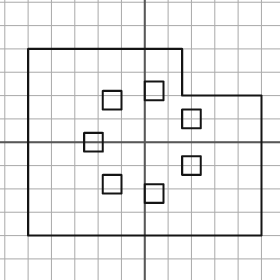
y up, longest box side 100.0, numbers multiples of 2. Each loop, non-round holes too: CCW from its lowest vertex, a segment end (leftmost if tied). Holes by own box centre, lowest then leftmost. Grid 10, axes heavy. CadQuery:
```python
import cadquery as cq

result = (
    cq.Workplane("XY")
    .moveTo(-50.0, -40.0)
    .lineTo(50.0, -40.0)
    .lineTo(50.0, 20.0)
    .lineTo(16.0, 20.0)
    .lineTo(16.0, 40.0)
    .lineTo(-50.0, 40.0)
    .close()
    .moveTo(0.0, -26.0)
    .lineTo(8.0, -26.0)
    .lineTo(8.0, -18.0)
    .lineTo(0.0, -18.0)
    .close()
    .moveTo(-18.0, -22.0)
    .lineTo(-10.0, -22.0)
    .lineTo(-10.0, -14.0)
    .lineTo(-18.0, -14.0)
    .close()
    .moveTo(16.0, -14.0)
    .lineTo(24.0, -14.0)
    .lineTo(24.0, -6.0)
    .lineTo(16.0, -6.0)
    .close()
    .moveTo(-26.0, -4.0)
    .lineTo(-18.0, -4.0)
    .lineTo(-18.0, 4.0)
    .lineTo(-26.0, 4.0)
    .close()
    .moveTo(16.0, 6.0)
    .lineTo(24.0, 6.0)
    .lineTo(24.0, 14.0)
    .lineTo(16.0, 14.0)
    .close()
    .moveTo(-18.0, 14.0)
    .lineTo(-10.0, 14.0)
    .lineTo(-10.0, 22.0)
    .lineTo(-18.0, 22.0)
    .close()
    .moveTo(0.0, 18.0)
    .lineTo(8.0, 18.0)
    .lineTo(8.0, 26.0)
    .lineTo(0.0, 26.0)
    .close()
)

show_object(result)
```